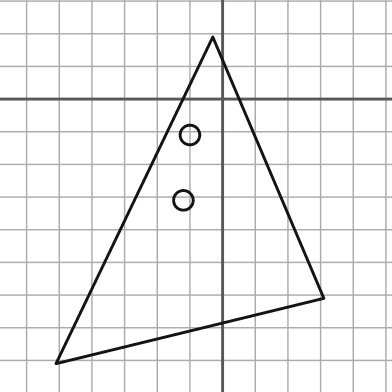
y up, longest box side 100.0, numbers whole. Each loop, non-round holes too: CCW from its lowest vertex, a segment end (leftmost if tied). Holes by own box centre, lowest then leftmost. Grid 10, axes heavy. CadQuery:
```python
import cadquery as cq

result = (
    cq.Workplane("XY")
    .moveTo(-51.0, -81.0)
    .lineTo(31.0, -61.0)
    .lineTo(-3.0, 19.0)
    .close()
    .moveTo(-12.0, -31.0)
    .circle(3.0)
    .moveTo(-10.0, -11.0)
    .circle(3.0)
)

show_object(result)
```